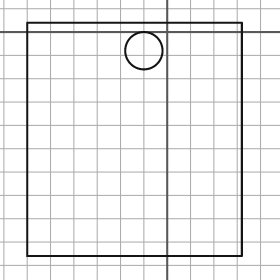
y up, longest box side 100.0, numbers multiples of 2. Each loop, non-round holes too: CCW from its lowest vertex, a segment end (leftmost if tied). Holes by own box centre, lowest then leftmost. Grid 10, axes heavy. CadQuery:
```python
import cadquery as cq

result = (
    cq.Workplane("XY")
    .moveTo(-60.0, -96.0)
    .lineTo(32.0, -96.0)
    .lineTo(32.0, 4.0)
    .lineTo(-60.0, 4.0)
    .close()
    .moveTo(-10.0, -8.0)
    .circle(8.0)
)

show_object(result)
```